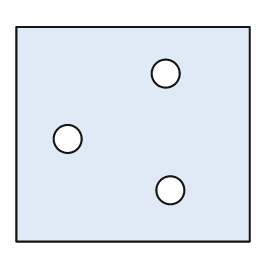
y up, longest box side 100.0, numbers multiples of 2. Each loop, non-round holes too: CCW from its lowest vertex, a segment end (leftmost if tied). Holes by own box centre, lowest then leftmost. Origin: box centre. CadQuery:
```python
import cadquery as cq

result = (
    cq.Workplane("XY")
    .moveTo(-50.0, -46.0)
    .lineTo(50.0, -46.0)
    .lineTo(50.0, 46.0)
    .lineTo(-50.0, 46.0)
    .close()
    .moveTo(16.0, -24.0)
    .circle(6.0)
    .moveTo(-28.0, -2.0)
    .circle(6.0)
    .moveTo(14.0, 26.0)
    .circle(6.0)
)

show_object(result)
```